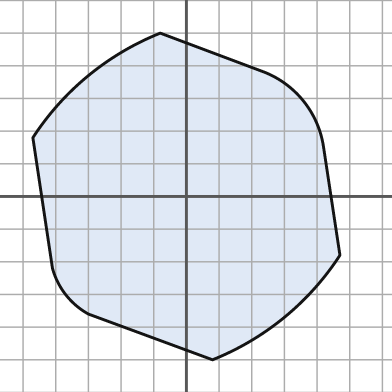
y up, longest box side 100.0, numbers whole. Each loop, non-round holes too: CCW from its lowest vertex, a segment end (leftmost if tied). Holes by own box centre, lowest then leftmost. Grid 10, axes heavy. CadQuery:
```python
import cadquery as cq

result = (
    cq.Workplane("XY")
    .moveTo(8.0, -50.0)
    .threePointArc((30.0, -37.0), (47.0, -18.0))
    .lineTo(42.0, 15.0)
    .threePointArc((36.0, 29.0), (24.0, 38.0))
    .lineTo(-8.0, 50.0)
    .threePointArc((-30.0, 37.0), (-47.0, 18.0))
    .lineTo(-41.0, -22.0)
    .threePointArc((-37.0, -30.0), (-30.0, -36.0))
    .close()
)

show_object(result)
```